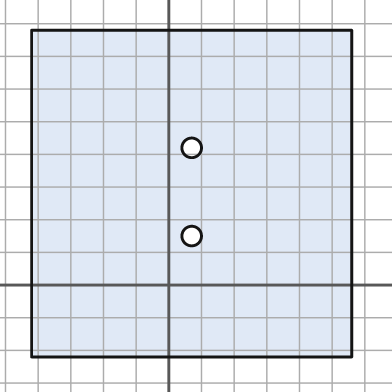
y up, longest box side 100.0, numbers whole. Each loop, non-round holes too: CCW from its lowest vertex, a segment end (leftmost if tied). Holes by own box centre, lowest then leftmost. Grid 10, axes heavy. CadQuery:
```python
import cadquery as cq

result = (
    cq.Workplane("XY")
    .moveTo(-42.0, -22.0)
    .lineTo(56.0, -22.0)
    .lineTo(56.0, 78.0)
    .lineTo(-42.0, 78.0)
    .close()
    .moveTo(7.0, 15.0)
    .circle(3.0)
    .moveTo(7.0, 42.0)
    .circle(3.0)
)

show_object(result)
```